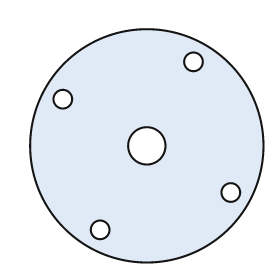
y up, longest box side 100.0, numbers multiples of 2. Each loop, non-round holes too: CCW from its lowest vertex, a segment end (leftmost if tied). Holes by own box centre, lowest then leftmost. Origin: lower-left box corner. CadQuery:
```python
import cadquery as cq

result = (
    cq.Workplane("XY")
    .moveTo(50.0, 50.0)
    .circle(50.0)
    .moveTo(30.0, 14.0)
    .circle(4.0)
    .moveTo(86.0, 30.0)
    .circle(4.0)
    .moveTo(50.0, 50.0)
    .circle(8.0)
    .moveTo(14.0, 70.0)
    .circle(4.0)
    .moveTo(70.0, 86.0)
    .circle(4.0)
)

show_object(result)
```